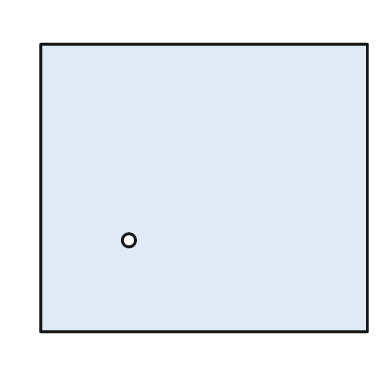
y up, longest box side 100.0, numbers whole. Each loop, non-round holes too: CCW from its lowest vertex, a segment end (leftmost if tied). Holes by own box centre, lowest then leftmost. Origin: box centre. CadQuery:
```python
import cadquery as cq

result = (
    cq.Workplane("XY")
    .moveTo(-50.0, -44.0)
    .lineTo(50.0, -44.0)
    .lineTo(50.0, 44.0)
    .lineTo(-50.0, 44.0)
    .close()
    .moveTo(-23.0, -16.0)
    .circle(2.0)
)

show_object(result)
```